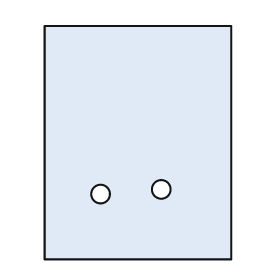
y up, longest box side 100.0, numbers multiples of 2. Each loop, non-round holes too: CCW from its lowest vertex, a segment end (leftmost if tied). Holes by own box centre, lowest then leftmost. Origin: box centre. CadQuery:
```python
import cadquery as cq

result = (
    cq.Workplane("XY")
    .moveTo(-40.0, -50.0)
    .lineTo(40.0, -50.0)
    .lineTo(40.0, 50.0)
    .lineTo(-40.0, 50.0)
    .close()
    .moveTo(-16.0, -22.0)
    .circle(4.0)
    .moveTo(10.0, -20.0)
    .circle(4.0)
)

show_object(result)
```